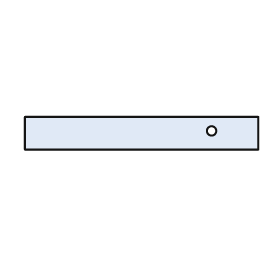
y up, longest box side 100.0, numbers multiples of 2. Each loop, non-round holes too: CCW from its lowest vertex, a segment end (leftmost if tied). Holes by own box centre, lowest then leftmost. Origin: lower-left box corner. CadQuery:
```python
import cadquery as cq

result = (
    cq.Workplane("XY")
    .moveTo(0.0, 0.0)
    .lineTo(100.0, 0.0)
    .lineTo(100.0, 14.0)
    .lineTo(0.0, 14.0)
    .close()
    .moveTo(80.0, 8.0)
    .circle(2.0)
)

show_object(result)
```